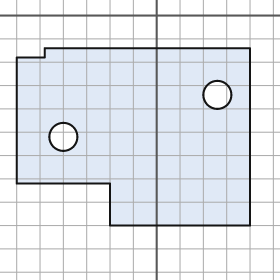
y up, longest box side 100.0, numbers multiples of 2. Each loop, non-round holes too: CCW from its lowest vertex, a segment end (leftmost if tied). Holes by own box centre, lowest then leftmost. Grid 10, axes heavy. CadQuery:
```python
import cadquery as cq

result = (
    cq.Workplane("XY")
    .moveTo(-20.0, -90.0)
    .lineTo(40.0, -90.0)
    .lineTo(40.0, -14.0)
    .lineTo(-48.0, -14.0)
    .lineTo(-48.0, -18.0)
    .lineTo(-60.0, -18.0)
    .lineTo(-60.0, -72.0)
    .lineTo(-20.0, -72.0)
    .close()
    .moveTo(-40.0, -52.0)
    .circle(6.0)
    .moveTo(26.0, -34.0)
    .circle(6.0)
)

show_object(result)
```